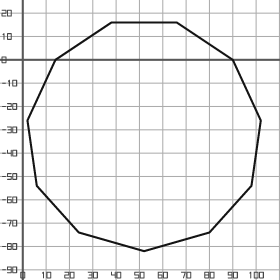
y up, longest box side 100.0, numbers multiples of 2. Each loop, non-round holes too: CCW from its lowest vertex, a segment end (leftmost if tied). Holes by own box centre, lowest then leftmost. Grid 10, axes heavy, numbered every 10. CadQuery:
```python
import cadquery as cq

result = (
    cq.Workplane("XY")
    .moveTo(52.0, -82.0)
    .lineTo(80.0, -74.0)
    .lineTo(98.0, -54.0)
    .lineTo(102.0, -26.0)
    .lineTo(90.0, 0.0)
    .lineTo(66.0, 16.0)
    .lineTo(38.0, 16.0)
    .lineTo(14.0, 0.0)
    .lineTo(2.0, -26.0)
    .lineTo(6.0, -54.0)
    .lineTo(24.0, -74.0)
    .close()
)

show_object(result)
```